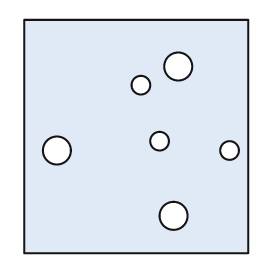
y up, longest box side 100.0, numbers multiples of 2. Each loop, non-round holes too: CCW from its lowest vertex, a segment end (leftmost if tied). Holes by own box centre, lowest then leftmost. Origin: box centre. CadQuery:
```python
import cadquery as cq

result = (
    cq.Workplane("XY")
    .moveTo(-48.0, -50.0)
    .lineTo(48.0, -50.0)
    .lineTo(48.0, 50.0)
    .lineTo(-48.0, 50.0)
    .close()
    .moveTo(16.0, -34.0)
    .circle(6.0)
    .moveTo(-34.0, -6.0)
    .circle(6.0)
    .moveTo(40.0, -6.0)
    .circle(4.0)
    .moveTo(10.0, -2.0)
    .circle(4.0)
    .moveTo(2.0, 22.0)
    .circle(4.0)
    .moveTo(18.0, 30.0)
    .circle(6.0)
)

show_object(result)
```